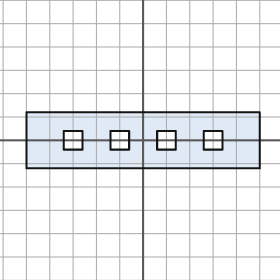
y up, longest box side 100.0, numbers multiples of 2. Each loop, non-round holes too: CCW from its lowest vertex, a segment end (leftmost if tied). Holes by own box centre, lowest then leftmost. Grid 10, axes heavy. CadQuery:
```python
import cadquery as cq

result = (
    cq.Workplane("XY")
    .moveTo(-50.0, -12.0)
    .lineTo(50.0, -12.0)
    .lineTo(50.0, 12.0)
    .lineTo(-50.0, 12.0)
    .close()
    .moveTo(-34.0, -4.0)
    .lineTo(-26.0, -4.0)
    .lineTo(-26.0, 4.0)
    .lineTo(-34.0, 4.0)
    .close()
    .moveTo(-14.0, -4.0)
    .lineTo(-6.0, -4.0)
    .lineTo(-6.0, 4.0)
    .lineTo(-14.0, 4.0)
    .close()
    .moveTo(6.0, -4.0)
    .lineTo(14.0, -4.0)
    .lineTo(14.0, 4.0)
    .lineTo(6.0, 4.0)
    .close()
    .moveTo(26.0, -4.0)
    .lineTo(34.0, -4.0)
    .lineTo(34.0, 4.0)
    .lineTo(26.0, 4.0)
    .close()
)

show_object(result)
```